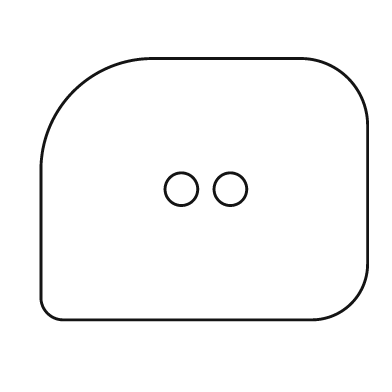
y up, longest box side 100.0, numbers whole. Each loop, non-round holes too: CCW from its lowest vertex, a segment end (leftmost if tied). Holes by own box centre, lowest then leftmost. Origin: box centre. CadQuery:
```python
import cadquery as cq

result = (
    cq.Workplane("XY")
    .moveTo(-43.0, -40.0)
    .lineTo(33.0, -40.0)
    .threePointArc((45.0, -35.0), (50.0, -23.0))
    .lineTo(50.0, 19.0)
    .threePointArc((44.0, 34.0), (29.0, 40.0))
    .lineTo(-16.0, 40.0)
    .threePointArc((-40.0, 30.0), (-50.0, 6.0))
    .lineTo(-50.0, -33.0)
    .threePointArc((-48.0, -38.0), (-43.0, -40.0))
    .close()
    .moveTo(-7.0, 0.0)
    .circle(5.0)
    .moveTo(8.0, 0.0)
    .circle(5.0)
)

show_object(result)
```